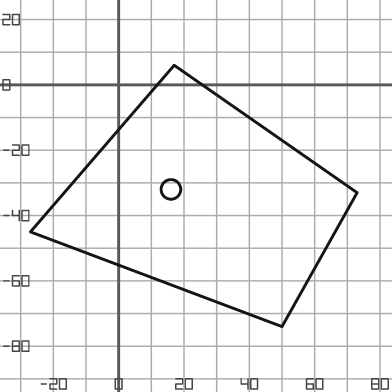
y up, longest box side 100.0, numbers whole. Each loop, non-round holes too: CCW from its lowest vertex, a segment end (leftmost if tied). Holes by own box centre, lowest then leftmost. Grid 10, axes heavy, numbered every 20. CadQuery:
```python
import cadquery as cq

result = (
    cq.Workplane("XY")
    .moveTo(50.0, -74.0)
    .lineTo(73.0, -33.0)
    .lineTo(17.0, 6.0)
    .lineTo(-27.0, -45.0)
    .close()
    .moveTo(16.0, -32.0)
    .circle(3.0)
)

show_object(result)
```